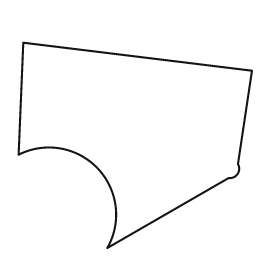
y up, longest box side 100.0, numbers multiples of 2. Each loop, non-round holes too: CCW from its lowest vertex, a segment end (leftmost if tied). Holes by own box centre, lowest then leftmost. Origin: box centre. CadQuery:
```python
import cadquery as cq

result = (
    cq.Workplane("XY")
    .moveTo(-12.0, -44.0)
    .lineTo(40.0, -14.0)
    .threePointArc((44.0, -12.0), (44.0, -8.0))
    .lineTo(50.0, 32.0)
    .lineTo(-48.0, 44.0)
    .lineTo(-50.0, -4.0)
    .threePointArc((-16.0, -10.0), (-12.0, -44.0))
    .close()
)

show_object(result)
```